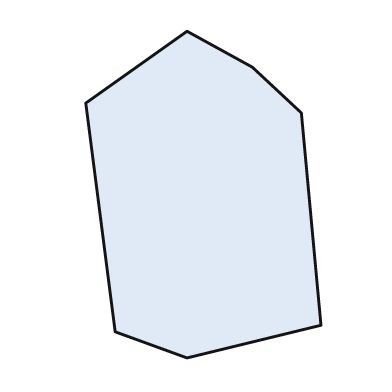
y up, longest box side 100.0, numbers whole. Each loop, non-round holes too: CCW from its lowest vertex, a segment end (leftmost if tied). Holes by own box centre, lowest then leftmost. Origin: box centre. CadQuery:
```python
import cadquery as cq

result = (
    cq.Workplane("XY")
    .moveTo(-5.0, -50.0)
    .lineTo(36.0, -40.0)
    .lineTo(30.0, 25.0)
    .lineTo(15.0, 39.0)
    .lineTo(-5.0, 50.0)
    .lineTo(-36.0, 28.0)
    .lineTo(-27.0, -42.0)
    .close()
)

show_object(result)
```